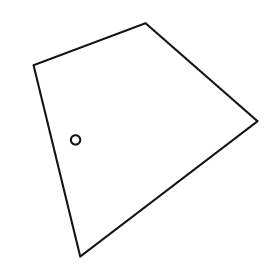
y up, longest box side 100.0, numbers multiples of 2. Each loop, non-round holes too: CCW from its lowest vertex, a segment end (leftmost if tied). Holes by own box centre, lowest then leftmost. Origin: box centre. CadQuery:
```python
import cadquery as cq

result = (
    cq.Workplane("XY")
    .moveTo(-28.0, -50.0)
    .lineTo(48.0, 8.0)
    .lineTo(0.0, 50.0)
    .lineTo(-48.0, 32.0)
    .close()
    .moveTo(-30.0, 0.0)
    .circle(2.0)
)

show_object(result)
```